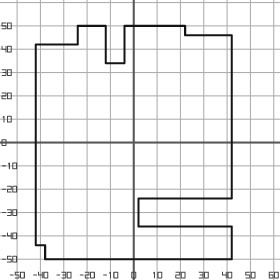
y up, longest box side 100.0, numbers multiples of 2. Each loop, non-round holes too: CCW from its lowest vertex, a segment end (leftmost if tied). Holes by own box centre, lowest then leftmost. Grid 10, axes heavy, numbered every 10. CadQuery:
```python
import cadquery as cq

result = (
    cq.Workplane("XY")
    .moveTo(-38.0, -50.0)
    .lineTo(42.0, -50.0)
    .lineTo(42.0, -36.0)
    .lineTo(2.0, -36.0)
    .lineTo(2.0, -24.0)
    .lineTo(42.0, -24.0)
    .lineTo(42.0, 46.0)
    .lineTo(22.0, 46.0)
    .lineTo(22.0, 50.0)
    .lineTo(-4.0, 50.0)
    .lineTo(-4.0, 34.0)
    .lineTo(-12.0, 34.0)
    .lineTo(-12.0, 50.0)
    .lineTo(-24.0, 50.0)
    .lineTo(-24.0, 42.0)
    .lineTo(-42.0, 42.0)
    .lineTo(-42.0, -44.0)
    .lineTo(-38.0, -44.0)
    .close()
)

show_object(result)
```